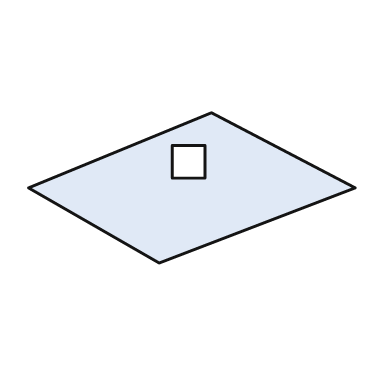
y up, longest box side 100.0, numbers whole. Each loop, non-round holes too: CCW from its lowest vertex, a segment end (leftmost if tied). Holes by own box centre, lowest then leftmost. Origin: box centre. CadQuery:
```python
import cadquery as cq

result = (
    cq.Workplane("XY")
    .moveTo(-10.0, -23.0)
    .lineTo(50.0, 0.0)
    .lineTo(6.0, 23.0)
    .lineTo(-50.0, 0.0)
    .close()
    .moveTo(-6.0, 3.0)
    .lineTo(4.0, 3.0)
    .lineTo(4.0, 13.0)
    .lineTo(-6.0, 13.0)
    .close()
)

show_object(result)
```